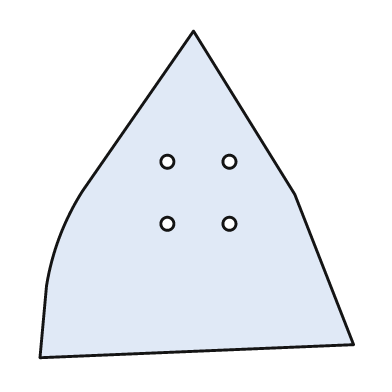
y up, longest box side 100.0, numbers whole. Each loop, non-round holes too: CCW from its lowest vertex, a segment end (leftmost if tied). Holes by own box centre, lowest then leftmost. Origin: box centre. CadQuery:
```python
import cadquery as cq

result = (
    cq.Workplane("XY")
    .moveTo(-48.0, -50.0)
    .lineTo(48.0, -46.0)
    .lineTo(30.0, 0.0)
    .lineTo(-1.0, 50.0)
    .lineTo(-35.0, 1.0)
    .threePointArc((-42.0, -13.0), (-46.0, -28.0))
    .close()
    .moveTo(-9.0, -9.0)
    .circle(2.0)
    .moveTo(10.0, -9.0)
    .circle(2.0)
    .moveTo(-9.0, 10.0)
    .circle(2.0)
    .moveTo(10.0, 10.0)
    .circle(2.0)
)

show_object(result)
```